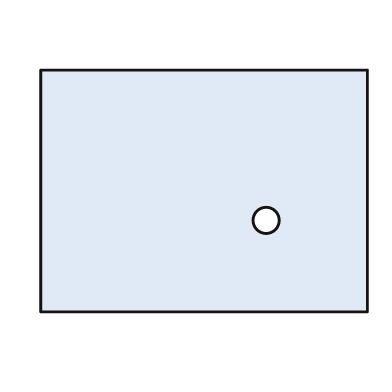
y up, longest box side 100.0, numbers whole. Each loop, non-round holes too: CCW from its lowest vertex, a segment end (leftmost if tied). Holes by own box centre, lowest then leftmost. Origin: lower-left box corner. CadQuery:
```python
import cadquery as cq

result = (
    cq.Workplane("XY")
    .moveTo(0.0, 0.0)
    .lineTo(100.0, 0.0)
    .lineTo(100.0, 74.0)
    .lineTo(0.0, 74.0)
    .close()
    .moveTo(69.0, 28.0)
    .circle(4.0)
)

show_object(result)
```